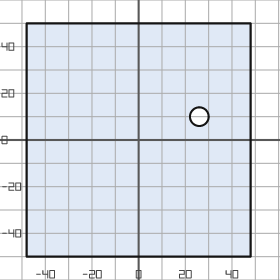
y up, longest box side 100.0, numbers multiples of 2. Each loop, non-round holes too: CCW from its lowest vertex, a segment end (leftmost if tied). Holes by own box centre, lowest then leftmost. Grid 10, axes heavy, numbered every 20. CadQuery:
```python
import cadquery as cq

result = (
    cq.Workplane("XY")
    .moveTo(-48.0, -50.0)
    .lineTo(48.0, -50.0)
    .lineTo(48.0, 50.0)
    .lineTo(-48.0, 50.0)
    .close()
    .moveTo(26.0, 10.0)
    .circle(4.0)
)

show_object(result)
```